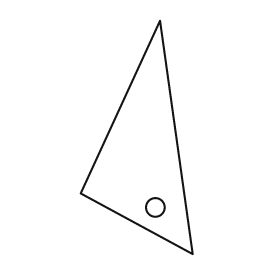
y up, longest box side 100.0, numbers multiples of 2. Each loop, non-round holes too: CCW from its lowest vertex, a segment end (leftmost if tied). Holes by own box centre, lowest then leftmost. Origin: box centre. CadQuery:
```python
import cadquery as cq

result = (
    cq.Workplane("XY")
    .moveTo(24.0, -50.0)
    .lineTo(10.0, 50.0)
    .lineTo(-24.0, -24.0)
    .close()
    .moveTo(8.0, -30.0)
    .circle(4.0)
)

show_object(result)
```